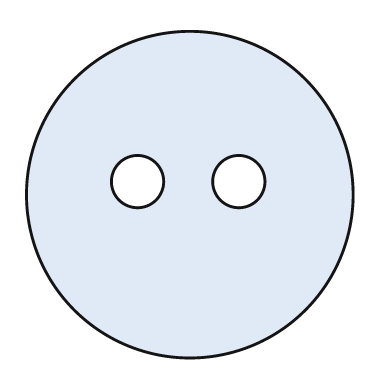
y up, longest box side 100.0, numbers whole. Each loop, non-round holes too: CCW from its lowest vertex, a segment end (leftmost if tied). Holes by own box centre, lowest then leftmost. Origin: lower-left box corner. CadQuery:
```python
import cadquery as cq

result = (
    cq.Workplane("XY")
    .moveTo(50.0, 50.0)
    .circle(50.0)
    .moveTo(34.0, 54.0)
    .circle(8.0)
    .moveTo(65.0, 54.0)
    .circle(8.0)
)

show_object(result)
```